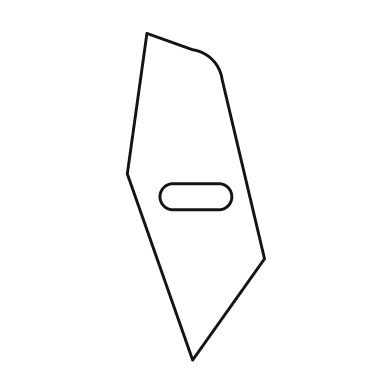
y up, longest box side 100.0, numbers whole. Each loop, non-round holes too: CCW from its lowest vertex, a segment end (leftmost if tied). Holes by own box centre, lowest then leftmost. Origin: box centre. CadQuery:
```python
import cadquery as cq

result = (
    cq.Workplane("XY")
    .moveTo(-1.0, -50.0)
    .lineTo(21.0, -19.0)
    .lineTo(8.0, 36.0)
    .threePointArc((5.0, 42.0), (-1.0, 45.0))
    .lineTo(-15.0, 50.0)
    .lineTo(-21.0, 7.0)
    .close()
    .moveTo(-7.0, -4.0)
    .lineTo(7.0, -4.0)
    .threePointArc((11.0, 0.0), (7.0, 4.0))
    .lineTo(-7.0, 4.0)
    .threePointArc((-11.0, 0.0), (-7.0, -4.0))
    .close()
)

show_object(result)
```